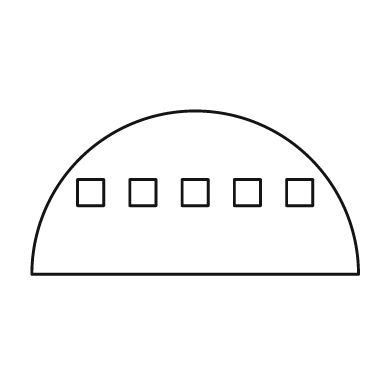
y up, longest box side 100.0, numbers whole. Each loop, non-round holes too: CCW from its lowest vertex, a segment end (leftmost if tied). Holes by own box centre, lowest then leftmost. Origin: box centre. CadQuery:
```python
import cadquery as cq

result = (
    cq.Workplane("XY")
    .moveTo(-50.0, -25.0)
    .lineTo(50.0, -25.0)
    .threePointArc((0.0, 25.0), (-50.0, -25.0))
    .close()
    .moveTo(-36.0, -4.0)
    .lineTo(-28.0, -4.0)
    .lineTo(-28.0, 4.0)
    .lineTo(-36.0, 4.0)
    .close()
    .moveTo(-20.0, -4.0)
    .lineTo(-12.0, -4.0)
    .lineTo(-12.0, 4.0)
    .lineTo(-20.0, 4.0)
    .close()
    .moveTo(-4.0, -4.0)
    .lineTo(4.0, -4.0)
    .lineTo(4.0, 4.0)
    .lineTo(-4.0, 4.0)
    .close()
    .moveTo(12.0, -4.0)
    .lineTo(20.0, -4.0)
    .lineTo(20.0, 4.0)
    .lineTo(12.0, 4.0)
    .close()
    .moveTo(28.0, -4.0)
    .lineTo(36.0, -4.0)
    .lineTo(36.0, 4.0)
    .lineTo(28.0, 4.0)
    .close()
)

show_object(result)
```